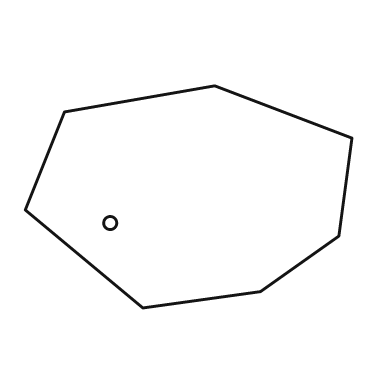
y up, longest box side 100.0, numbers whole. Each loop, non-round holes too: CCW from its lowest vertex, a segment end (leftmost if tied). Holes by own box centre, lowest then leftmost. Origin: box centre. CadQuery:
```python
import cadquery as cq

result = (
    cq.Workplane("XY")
    .moveTo(-14.0, -34.0)
    .lineTo(22.0, -29.0)
    .lineTo(46.0, -12.0)
    .lineTo(50.0, 18.0)
    .lineTo(8.0, 34.0)
    .lineTo(-38.0, 26.0)
    .lineTo(-50.0, -4.0)
    .close()
    .moveTo(-24.0, -8.0)
    .circle(2.0)
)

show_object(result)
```